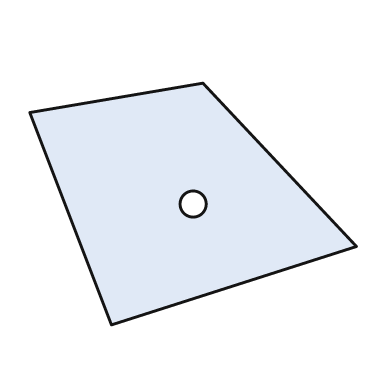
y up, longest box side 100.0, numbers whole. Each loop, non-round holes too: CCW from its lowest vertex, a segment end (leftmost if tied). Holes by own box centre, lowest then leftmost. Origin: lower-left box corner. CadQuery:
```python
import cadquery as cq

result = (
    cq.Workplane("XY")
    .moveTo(25.0, 0.0)
    .lineTo(100.0, 24.0)
    .lineTo(53.0, 74.0)
    .lineTo(0.0, 65.0)
    .close()
    .moveTo(50.0, 37.0)
    .circle(4.0)
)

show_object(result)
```